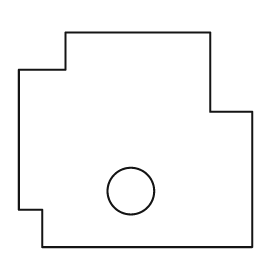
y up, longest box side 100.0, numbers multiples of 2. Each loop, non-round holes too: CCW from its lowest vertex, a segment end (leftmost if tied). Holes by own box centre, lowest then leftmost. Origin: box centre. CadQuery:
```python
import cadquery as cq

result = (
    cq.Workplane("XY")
    .moveTo(-40.0, -46.0)
    .lineTo(50.0, -46.0)
    .lineTo(50.0, 12.0)
    .lineTo(32.0, 12.0)
    .lineTo(32.0, 46.0)
    .lineTo(-30.0, 46.0)
    .lineTo(-30.0, 30.0)
    .lineTo(-50.0, 30.0)
    .lineTo(-50.0, -30.0)
    .lineTo(-40.0, -30.0)
    .close()
    .moveTo(-2.0, -22.0)
    .circle(10.0)
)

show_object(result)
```